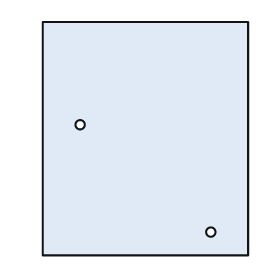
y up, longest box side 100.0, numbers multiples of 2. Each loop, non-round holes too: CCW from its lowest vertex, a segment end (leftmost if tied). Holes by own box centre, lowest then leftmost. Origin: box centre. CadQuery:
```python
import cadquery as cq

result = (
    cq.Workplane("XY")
    .moveTo(-44.0, -50.0)
    .lineTo(44.0, -50.0)
    .lineTo(44.0, 50.0)
    .lineTo(-44.0, 50.0)
    .close()
    .moveTo(28.0, -40.0)
    .circle(2.0)
    .moveTo(-28.0, 6.0)
    .circle(2.0)
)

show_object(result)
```